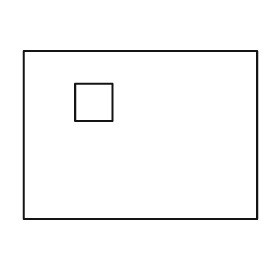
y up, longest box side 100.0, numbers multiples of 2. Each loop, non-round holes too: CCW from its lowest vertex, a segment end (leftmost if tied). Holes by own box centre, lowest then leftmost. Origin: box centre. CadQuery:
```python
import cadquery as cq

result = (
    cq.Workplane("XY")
    .moveTo(-50.0, -36.0)
    .lineTo(50.0, -36.0)
    .lineTo(50.0, 36.0)
    .lineTo(-50.0, 36.0)
    .close()
    .moveTo(-28.0, 6.0)
    .lineTo(-12.0, 6.0)
    .lineTo(-12.0, 22.0)
    .lineTo(-28.0, 22.0)
    .close()
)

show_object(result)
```